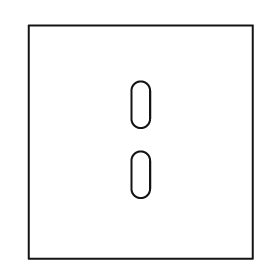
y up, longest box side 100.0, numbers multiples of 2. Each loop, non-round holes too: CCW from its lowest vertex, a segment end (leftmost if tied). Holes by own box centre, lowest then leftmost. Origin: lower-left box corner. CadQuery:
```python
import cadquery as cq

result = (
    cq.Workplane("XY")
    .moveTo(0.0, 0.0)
    .lineTo(96.0, 0.0)
    .lineTo(96.0, 100.0)
    .lineTo(0.0, 100.0)
    .close()
    .moveTo(44.0, 30.0)
    .threePointArc((48.0, 26.0), (52.0, 30.0))
    .lineTo(52.0, 42.0)
    .threePointArc((48.0, 46.0), (44.0, 42.0))
    .close()
    .moveTo(44.0, 60.0)
    .threePointArc((48.0, 56.0), (52.0, 60.0))
    .lineTo(52.0, 72.0)
    .threePointArc((48.0, 76.0), (44.0, 72.0))
    .close()
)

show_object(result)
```